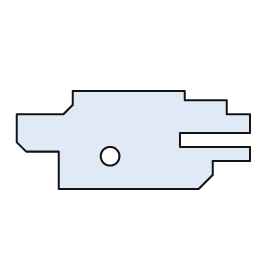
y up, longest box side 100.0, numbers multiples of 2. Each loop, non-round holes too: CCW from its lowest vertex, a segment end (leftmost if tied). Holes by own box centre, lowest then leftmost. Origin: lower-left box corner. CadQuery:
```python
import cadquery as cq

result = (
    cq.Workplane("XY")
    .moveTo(18.0, 0.0)
    .lineTo(78.0, 0.0)
    .lineTo(84.0, 6.0)
    .lineTo(84.0, 12.0)
    .lineTo(100.0, 12.0)
    .lineTo(100.0, 18.0)
    .lineTo(70.0, 18.0)
    .lineTo(70.0, 24.0)
    .lineTo(100.0, 24.0)
    .lineTo(100.0, 32.0)
    .lineTo(90.0, 32.0)
    .lineTo(90.0, 38.0)
    .lineTo(72.0, 38.0)
    .lineTo(72.0, 42.0)
    .lineTo(24.0, 42.0)
    .lineTo(24.0, 36.0)
    .lineTo(20.0, 32.0)
    .lineTo(0.0, 32.0)
    .lineTo(0.0, 20.0)
    .lineTo(4.0, 16.0)
    .lineTo(18.0, 16.0)
    .close()
    .moveTo(40.0, 14.0)
    .circle(4.0)
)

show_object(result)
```